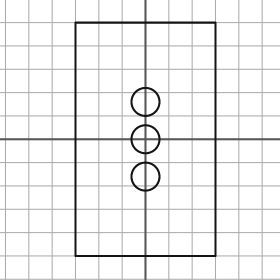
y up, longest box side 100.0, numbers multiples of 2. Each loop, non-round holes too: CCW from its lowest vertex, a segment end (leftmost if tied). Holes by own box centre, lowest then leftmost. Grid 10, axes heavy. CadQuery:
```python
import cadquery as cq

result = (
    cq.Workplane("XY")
    .moveTo(-30.0, -50.0)
    .lineTo(30.0, -50.0)
    .lineTo(30.0, 50.0)
    .lineTo(-30.0, 50.0)
    .close()
    .moveTo(0.0, -16.0)
    .circle(6.0)
    .moveTo(0.0, 0.0)
    .circle(6.0)
    .moveTo(0.0, 16.0)
    .circle(6.0)
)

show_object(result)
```